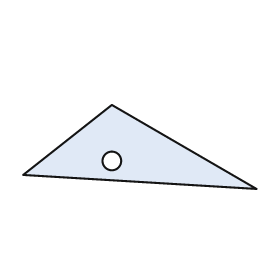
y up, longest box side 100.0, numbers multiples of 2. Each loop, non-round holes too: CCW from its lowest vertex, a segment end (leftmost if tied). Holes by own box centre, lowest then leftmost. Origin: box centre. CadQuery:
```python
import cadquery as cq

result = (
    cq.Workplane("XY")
    .moveTo(50.0, -18.0)
    .lineTo(-12.0, 18.0)
    .lineTo(-50.0, -12.0)
    .close()
    .moveTo(-12.0, -6.0)
    .circle(4.0)
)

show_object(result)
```